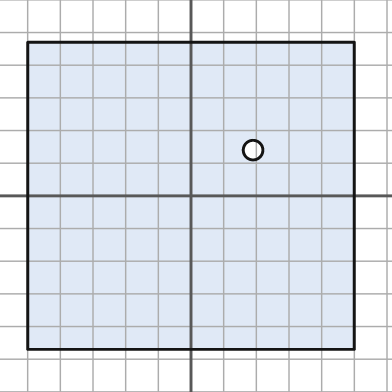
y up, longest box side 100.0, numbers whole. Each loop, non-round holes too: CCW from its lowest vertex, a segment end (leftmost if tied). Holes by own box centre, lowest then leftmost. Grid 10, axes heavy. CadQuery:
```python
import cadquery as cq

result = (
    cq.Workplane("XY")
    .moveTo(-50.0, -47.0)
    .lineTo(50.0, -47.0)
    .lineTo(50.0, 47.0)
    .lineTo(-50.0, 47.0)
    .close()
    .moveTo(19.0, 14.0)
    .circle(3.0)
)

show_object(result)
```